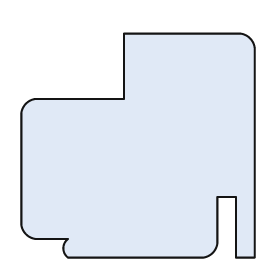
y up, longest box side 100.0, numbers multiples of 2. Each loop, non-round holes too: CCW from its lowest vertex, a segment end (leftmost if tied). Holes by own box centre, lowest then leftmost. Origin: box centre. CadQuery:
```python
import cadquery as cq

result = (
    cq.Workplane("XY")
    .moveTo(-30.0, -48.0)
    .lineTo(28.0, -48.0)
    .threePointArc((32.0, -46.0), (34.0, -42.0))
    .lineTo(34.0, -22.0)
    .lineTo(42.0, -22.0)
    .lineTo(42.0, -48.0)
    .lineTo(50.0, -48.0)
    .lineTo(50.0, 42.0)
    .threePointArc((48.0, 46.0), (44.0, 48.0))
    .lineTo(-6.0, 48.0)
    .lineTo(-6.0, 20.0)
    .lineTo(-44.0, 20.0)
    .threePointArc((-48.0, 18.0), (-50.0, 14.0))
    .lineTo(-50.0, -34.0)
    .threePointArc((-48.0, -38.0), (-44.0, -40.0))
    .lineTo(-30.0, -40.0)
    .threePointArc((-32.0, -44.0), (-30.0, -48.0))
    .close()
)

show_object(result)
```